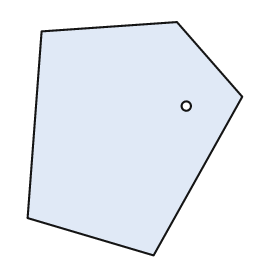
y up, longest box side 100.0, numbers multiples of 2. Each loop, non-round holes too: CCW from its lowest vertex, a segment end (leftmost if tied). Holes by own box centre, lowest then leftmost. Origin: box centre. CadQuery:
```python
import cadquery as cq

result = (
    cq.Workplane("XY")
    .moveTo(8.0, -50.0)
    .lineTo(46.0, 18.0)
    .lineTo(18.0, 50.0)
    .lineTo(-40.0, 46.0)
    .lineTo(-46.0, -34.0)
    .close()
    .moveTo(22.0, 14.0)
    .circle(2.0)
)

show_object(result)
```